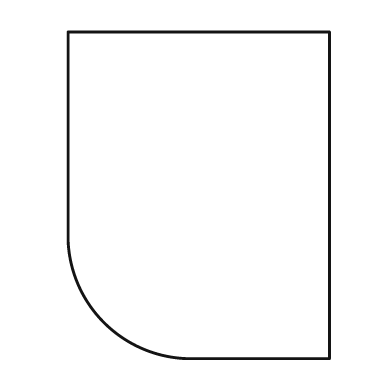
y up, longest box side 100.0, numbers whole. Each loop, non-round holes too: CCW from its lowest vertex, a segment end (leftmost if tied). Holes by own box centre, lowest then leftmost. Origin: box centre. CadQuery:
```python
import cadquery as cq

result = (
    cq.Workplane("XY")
    .moveTo(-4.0, -50.0)
    .lineTo(40.0, -50.0)
    .lineTo(40.0, 50.0)
    .lineTo(-40.0, 50.0)
    .lineTo(-40.0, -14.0)
    .threePointArc((-29.0, -39.0), (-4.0, -50.0))
    .close()
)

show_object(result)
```